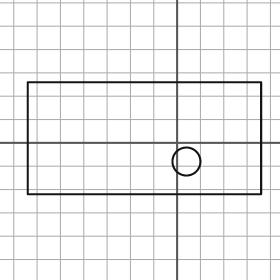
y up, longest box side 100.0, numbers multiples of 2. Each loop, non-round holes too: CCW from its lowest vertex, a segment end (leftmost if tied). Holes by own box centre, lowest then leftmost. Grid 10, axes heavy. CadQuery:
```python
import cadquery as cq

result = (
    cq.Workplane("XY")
    .moveTo(-64.0, -22.0)
    .lineTo(36.0, -22.0)
    .lineTo(36.0, 26.0)
    .lineTo(-64.0, 26.0)
    .close()
    .moveTo(4.0, -8.0)
    .circle(6.0)
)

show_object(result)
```